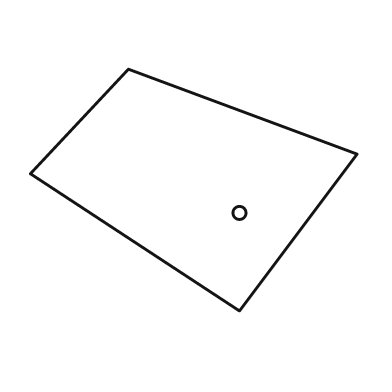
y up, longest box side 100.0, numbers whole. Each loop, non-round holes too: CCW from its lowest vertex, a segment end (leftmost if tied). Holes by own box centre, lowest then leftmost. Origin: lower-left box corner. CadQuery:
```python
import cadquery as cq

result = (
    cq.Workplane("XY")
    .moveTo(64.0, 0.0)
    .lineTo(100.0, 48.0)
    .lineTo(30.0, 74.0)
    .lineTo(0.0, 42.0)
    .close()
    .moveTo(64.0, 30.0)
    .circle(2.0)
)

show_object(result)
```